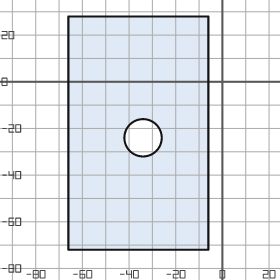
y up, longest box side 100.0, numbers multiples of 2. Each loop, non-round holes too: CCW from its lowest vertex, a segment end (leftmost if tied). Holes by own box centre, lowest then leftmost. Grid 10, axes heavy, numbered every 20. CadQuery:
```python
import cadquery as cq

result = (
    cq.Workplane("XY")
    .moveTo(-66.0, -72.0)
    .lineTo(-6.0, -72.0)
    .lineTo(-6.0, 28.0)
    .lineTo(-66.0, 28.0)
    .close()
    .moveTo(-34.0, -24.0)
    .circle(8.0)
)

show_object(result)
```